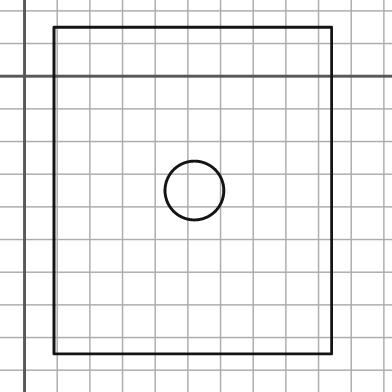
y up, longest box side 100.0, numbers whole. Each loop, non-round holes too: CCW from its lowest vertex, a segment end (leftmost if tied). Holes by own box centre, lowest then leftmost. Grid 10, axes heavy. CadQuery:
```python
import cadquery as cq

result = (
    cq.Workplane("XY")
    .moveTo(9.0, -85.0)
    .lineTo(94.0, -85.0)
    .lineTo(94.0, 15.0)
    .lineTo(9.0, 15.0)
    .close()
    .moveTo(52.0, -35.0)
    .circle(9.0)
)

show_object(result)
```